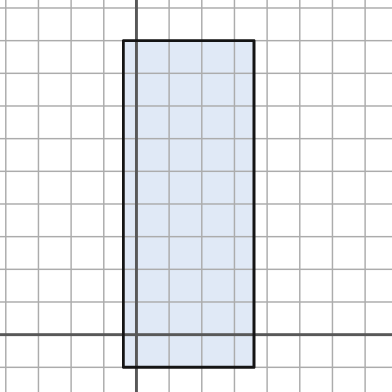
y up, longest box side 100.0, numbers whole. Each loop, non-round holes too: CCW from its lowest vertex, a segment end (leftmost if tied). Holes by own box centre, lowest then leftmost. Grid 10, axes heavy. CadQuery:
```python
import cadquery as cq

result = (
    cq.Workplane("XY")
    .moveTo(-4.0, -10.0)
    .lineTo(36.0, -10.0)
    .lineTo(36.0, 90.0)
    .lineTo(-4.0, 90.0)
    .close()
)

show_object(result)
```